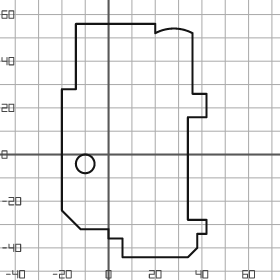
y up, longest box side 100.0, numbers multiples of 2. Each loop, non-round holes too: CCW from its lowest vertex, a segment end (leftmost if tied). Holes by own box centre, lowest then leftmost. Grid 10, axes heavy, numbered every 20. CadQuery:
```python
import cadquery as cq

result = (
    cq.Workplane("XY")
    .moveTo(6.0, -44.0)
    .lineTo(34.0, -44.0)
    .lineTo(38.0, -40.0)
    .lineTo(38.0, -34.0)
    .lineTo(42.0, -34.0)
    .lineTo(42.0, -28.0)
    .lineTo(34.0, -28.0)
    .lineTo(34.0, 16.0)
    .lineTo(42.0, 16.0)
    .lineTo(42.0, 26.0)
    .lineTo(36.0, 26.0)
    .lineTo(36.0, 52.0)
    .threePointArc((28.0, 54.0), (20.0, 52.0))
    .lineTo(20.0, 56.0)
    .lineTo(-14.0, 56.0)
    .lineTo(-14.0, 28.0)
    .lineTo(-20.0, 28.0)
    .lineTo(-20.0, -24.0)
    .lineTo(-12.0, -32.0)
    .lineTo(0.0, -32.0)
    .lineTo(0.0, -36.0)
    .lineTo(6.0, -36.0)
    .close()
    .moveTo(-10.0, -4.0)
    .circle(4.0)
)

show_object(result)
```